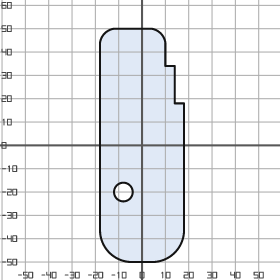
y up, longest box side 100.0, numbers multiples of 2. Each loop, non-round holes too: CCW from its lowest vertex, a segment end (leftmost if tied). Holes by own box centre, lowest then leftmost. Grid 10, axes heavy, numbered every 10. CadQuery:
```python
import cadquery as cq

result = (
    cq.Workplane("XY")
    .moveTo(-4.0, -50.0)
    .lineTo(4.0, -50.0)
    .threePointArc((14.0, -46.0), (18.0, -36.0))
    .lineTo(18.0, 18.0)
    .lineTo(14.0, 18.0)
    .lineTo(14.0, 34.0)
    .lineTo(10.0, 34.0)
    .lineTo(10.0, 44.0)
    .threePointArc((8.0, 48.0), (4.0, 50.0))
    .lineTo(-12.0, 50.0)
    .threePointArc((-16.0, 48.0), (-18.0, 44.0))
    .lineTo(-18.0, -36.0)
    .threePointArc((-14.0, -46.0), (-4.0, -50.0))
    .close()
    .moveTo(-8.0, -20.0)
    .circle(4.0)
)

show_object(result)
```